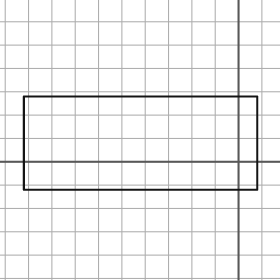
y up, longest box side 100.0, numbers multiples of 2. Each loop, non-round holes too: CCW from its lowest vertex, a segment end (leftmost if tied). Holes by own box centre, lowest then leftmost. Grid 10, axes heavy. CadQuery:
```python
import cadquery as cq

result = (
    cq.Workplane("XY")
    .moveTo(-92.0, -12.0)
    .lineTo(8.0, -12.0)
    .lineTo(8.0, 28.0)
    .lineTo(-92.0, 28.0)
    .close()
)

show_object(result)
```